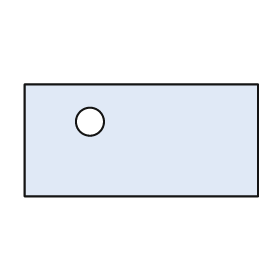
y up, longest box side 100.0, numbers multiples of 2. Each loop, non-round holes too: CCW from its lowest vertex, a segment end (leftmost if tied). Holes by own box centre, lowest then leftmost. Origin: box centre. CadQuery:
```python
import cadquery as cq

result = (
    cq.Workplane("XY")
    .moveTo(-50.0, -24.0)
    .lineTo(50.0, -24.0)
    .lineTo(50.0, 24.0)
    .lineTo(-50.0, 24.0)
    .close()
    .moveTo(-22.0, 8.0)
    .circle(6.0)
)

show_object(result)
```